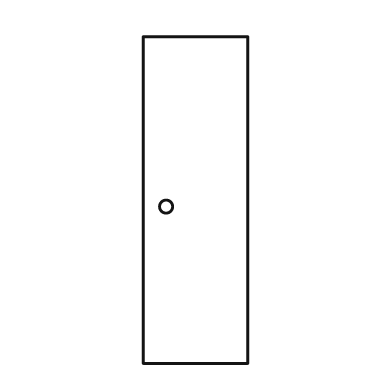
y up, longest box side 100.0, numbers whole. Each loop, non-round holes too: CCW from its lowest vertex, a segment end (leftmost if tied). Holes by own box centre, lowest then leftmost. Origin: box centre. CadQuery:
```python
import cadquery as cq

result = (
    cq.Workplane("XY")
    .moveTo(-16.0, -50.0)
    .lineTo(16.0, -50.0)
    .lineTo(16.0, 50.0)
    .lineTo(-16.0, 50.0)
    .close()
    .moveTo(-9.0, -2.0)
    .circle(2.0)
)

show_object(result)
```